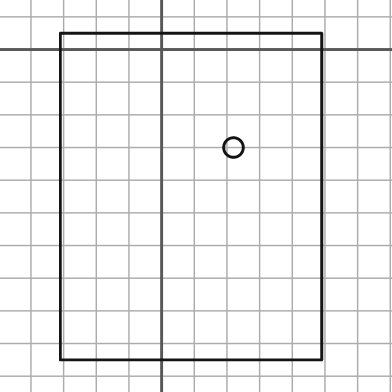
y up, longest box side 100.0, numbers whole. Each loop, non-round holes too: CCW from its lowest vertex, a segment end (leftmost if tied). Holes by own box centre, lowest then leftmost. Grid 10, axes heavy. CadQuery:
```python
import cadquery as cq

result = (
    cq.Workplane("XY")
    .moveTo(-31.0, -95.0)
    .lineTo(49.0, -95.0)
    .lineTo(49.0, 5.0)
    .lineTo(-31.0, 5.0)
    .close()
    .moveTo(22.0, -30.0)
    .circle(3.0)
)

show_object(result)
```